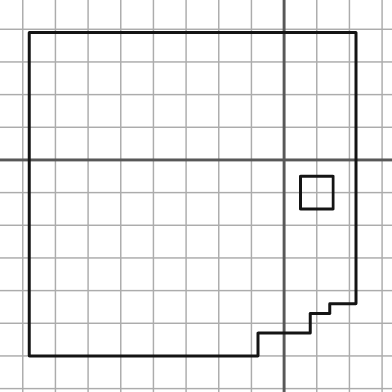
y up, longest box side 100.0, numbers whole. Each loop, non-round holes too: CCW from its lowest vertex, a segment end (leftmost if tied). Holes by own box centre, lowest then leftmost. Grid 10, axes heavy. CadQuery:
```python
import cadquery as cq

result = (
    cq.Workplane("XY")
    .moveTo(-78.0, -60.0)
    .lineTo(-8.0, -60.0)
    .lineTo(-8.0, -53.0)
    .lineTo(8.0, -53.0)
    .lineTo(8.0, -47.0)
    .lineTo(14.0, -47.0)
    .lineTo(14.0, -44.0)
    .lineTo(22.0, -44.0)
    .lineTo(22.0, 39.0)
    .lineTo(-78.0, 39.0)
    .close()
    .moveTo(5.0, -15.0)
    .lineTo(15.0, -15.0)
    .lineTo(15.0, -5.0)
    .lineTo(5.0, -5.0)
    .close()
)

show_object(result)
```